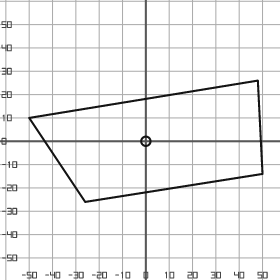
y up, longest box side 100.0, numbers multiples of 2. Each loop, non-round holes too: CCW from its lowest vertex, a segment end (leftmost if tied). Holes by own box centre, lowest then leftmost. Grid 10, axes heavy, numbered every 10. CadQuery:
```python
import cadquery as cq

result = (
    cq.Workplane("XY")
    .moveTo(-26.0, -26.0)
    .lineTo(50.0, -14.0)
    .lineTo(48.0, 26.0)
    .lineTo(-50.0, 10.0)
    .close()
    .moveTo(0.0, 0.0)
    .circle(2.0)
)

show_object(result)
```